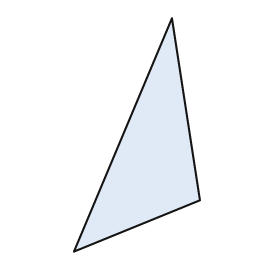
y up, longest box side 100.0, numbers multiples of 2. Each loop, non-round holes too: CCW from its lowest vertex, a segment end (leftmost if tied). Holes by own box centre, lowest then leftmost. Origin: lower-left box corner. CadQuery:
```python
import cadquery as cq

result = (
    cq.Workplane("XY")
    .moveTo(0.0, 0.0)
    .lineTo(54.0, 22.0)
    .lineTo(42.0, 100.0)
    .close()
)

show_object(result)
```